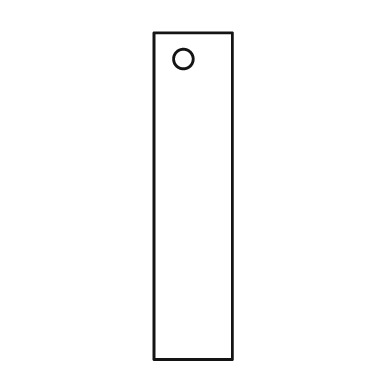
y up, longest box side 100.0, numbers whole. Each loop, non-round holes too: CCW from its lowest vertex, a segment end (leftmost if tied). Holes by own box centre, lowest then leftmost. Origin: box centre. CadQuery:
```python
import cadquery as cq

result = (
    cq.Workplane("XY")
    .moveTo(-12.0, -50.0)
    .lineTo(12.0, -50.0)
    .lineTo(12.0, 50.0)
    .lineTo(-12.0, 50.0)
    .close()
    .moveTo(-3.0, 42.0)
    .circle(3.0)
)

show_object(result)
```